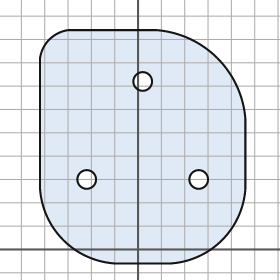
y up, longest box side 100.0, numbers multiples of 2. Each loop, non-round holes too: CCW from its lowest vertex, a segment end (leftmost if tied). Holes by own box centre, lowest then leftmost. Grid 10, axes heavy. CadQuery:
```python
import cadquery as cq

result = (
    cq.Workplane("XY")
    .moveTo(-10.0, -6.0)
    .lineTo(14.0, -6.0)
    .threePointArc((36.0, 4.0), (46.0, 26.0))
    .lineTo(46.0, 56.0)
    .threePointArc((34.0, 82.0), (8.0, 94.0))
    .lineTo(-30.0, 94.0)
    .threePointArc((-38.0, 90.0), (-42.0, 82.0))
    .lineTo(-42.0, 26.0)
    .threePointArc((-32.0, 4.0), (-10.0, -6.0))
    .close()
    .moveTo(-22.0, 30.0)
    .circle(4.0)
    .moveTo(26.0, 30.0)
    .circle(4.0)
    .moveTo(2.0, 72.0)
    .circle(4.0)
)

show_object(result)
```